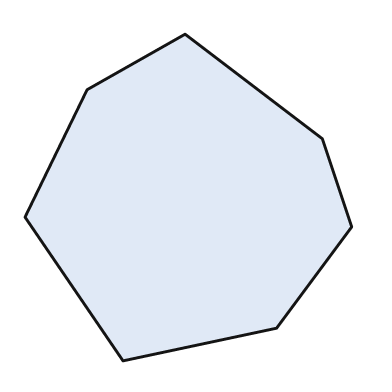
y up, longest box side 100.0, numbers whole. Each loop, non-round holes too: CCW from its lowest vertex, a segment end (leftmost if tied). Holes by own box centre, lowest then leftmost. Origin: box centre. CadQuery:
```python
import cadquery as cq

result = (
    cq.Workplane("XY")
    .moveTo(-20.0, -50.0)
    .lineTo(27.0, -40.0)
    .lineTo(50.0, -9.0)
    .lineTo(41.0, 18.0)
    .lineTo(-1.0, 50.0)
    .lineTo(-31.0, 33.0)
    .lineTo(-50.0, -6.0)
    .close()
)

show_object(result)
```